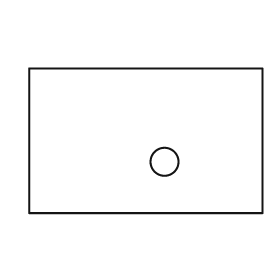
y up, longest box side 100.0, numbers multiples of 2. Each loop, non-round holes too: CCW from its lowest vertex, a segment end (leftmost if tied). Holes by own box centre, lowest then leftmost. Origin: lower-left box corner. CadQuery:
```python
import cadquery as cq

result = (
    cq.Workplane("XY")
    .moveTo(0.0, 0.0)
    .lineTo(100.0, 0.0)
    .lineTo(100.0, 62.0)
    .lineTo(0.0, 62.0)
    .close()
    .moveTo(58.0, 22.0)
    .circle(6.0)
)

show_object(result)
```